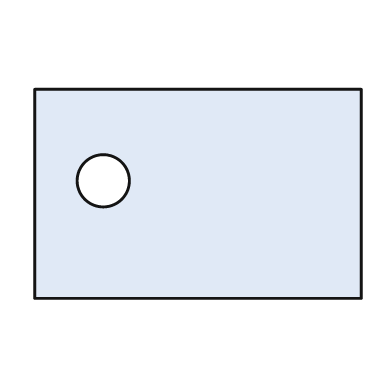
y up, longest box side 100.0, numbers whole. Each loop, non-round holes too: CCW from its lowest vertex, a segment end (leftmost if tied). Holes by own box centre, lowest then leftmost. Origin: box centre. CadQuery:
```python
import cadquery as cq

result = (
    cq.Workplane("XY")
    .moveTo(-50.0, -32.0)
    .lineTo(50.0, -32.0)
    .lineTo(50.0, 32.0)
    .lineTo(-50.0, 32.0)
    .close()
    .moveTo(-29.0, 4.0)
    .circle(8.0)
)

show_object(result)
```